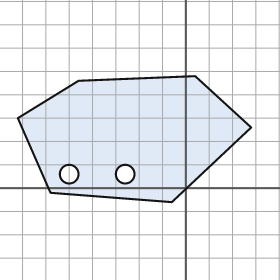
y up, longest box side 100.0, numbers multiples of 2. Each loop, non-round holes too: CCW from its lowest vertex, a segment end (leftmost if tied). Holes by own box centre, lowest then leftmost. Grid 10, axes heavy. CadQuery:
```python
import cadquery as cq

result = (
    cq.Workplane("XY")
    .moveTo(-6.0, -6.0)
    .lineTo(28.0, 26.0)
    .lineTo(4.0, 48.0)
    .lineTo(-46.0, 46.0)
    .lineTo(-72.0, 30.0)
    .lineTo(-58.0, -2.0)
    .close()
    .moveTo(-50.0, 6.0)
    .circle(4.0)
    .moveTo(-26.0, 6.0)
    .circle(4.0)
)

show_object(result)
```